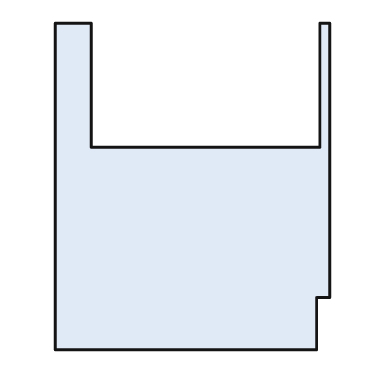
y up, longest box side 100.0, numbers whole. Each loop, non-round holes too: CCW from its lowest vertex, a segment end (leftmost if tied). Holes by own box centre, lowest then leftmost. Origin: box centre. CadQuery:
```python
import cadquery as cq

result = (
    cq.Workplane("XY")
    .moveTo(-42.0, -50.0)
    .lineTo(38.0, -50.0)
    .lineTo(38.0, -34.0)
    .lineTo(42.0, -34.0)
    .lineTo(42.0, 50.0)
    .lineTo(39.0, 50.0)
    .lineTo(39.0, 12.0)
    .lineTo(-31.0, 12.0)
    .lineTo(-31.0, 50.0)
    .lineTo(-42.0, 50.0)
    .close()
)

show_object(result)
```